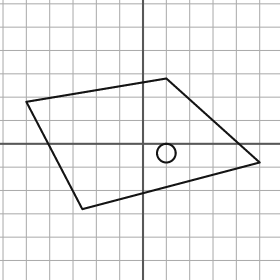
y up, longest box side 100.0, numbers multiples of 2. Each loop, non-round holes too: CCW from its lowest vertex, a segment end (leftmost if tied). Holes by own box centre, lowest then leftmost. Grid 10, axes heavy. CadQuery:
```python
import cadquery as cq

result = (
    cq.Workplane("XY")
    .moveTo(-26.0, -28.0)
    .lineTo(50.0, -8.0)
    .lineTo(10.0, 28.0)
    .lineTo(-50.0, 18.0)
    .close()
    .moveTo(10.0, -4.0)
    .circle(4.0)
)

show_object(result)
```